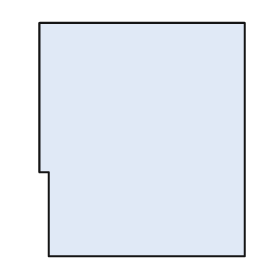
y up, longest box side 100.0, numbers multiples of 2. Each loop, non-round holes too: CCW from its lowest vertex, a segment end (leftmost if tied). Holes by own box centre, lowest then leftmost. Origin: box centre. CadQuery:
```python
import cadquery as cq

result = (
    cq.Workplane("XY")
    .moveTo(-40.0, -50.0)
    .lineTo(44.0, -50.0)
    .lineTo(44.0, 50.0)
    .lineTo(-44.0, 50.0)
    .lineTo(-44.0, -14.0)
    .lineTo(-40.0, -14.0)
    .close()
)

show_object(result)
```